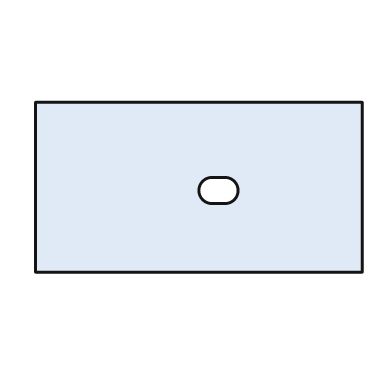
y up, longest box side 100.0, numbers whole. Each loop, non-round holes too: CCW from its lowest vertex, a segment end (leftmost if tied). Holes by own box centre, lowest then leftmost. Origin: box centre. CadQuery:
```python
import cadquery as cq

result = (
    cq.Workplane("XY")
    .moveTo(-50.0, -26.0)
    .lineTo(50.0, -26.0)
    .lineTo(50.0, 26.0)
    .lineTo(-50.0, 26.0)
    .close()
    .moveTo(4.0, -5.0)
    .lineTo(8.0, -5.0)
    .threePointArc((12.0, -1.0), (8.0, 3.0))
    .lineTo(4.0, 3.0)
    .threePointArc((0.0, -1.0), (4.0, -5.0))
    .close()
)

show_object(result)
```